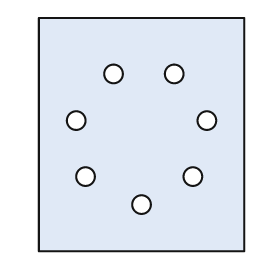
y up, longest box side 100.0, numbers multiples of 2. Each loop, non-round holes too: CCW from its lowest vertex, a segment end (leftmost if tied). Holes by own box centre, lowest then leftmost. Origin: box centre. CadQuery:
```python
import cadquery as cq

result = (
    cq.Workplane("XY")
    .moveTo(-44.0, -50.0)
    .lineTo(44.0, -50.0)
    .lineTo(44.0, 50.0)
    .lineTo(-44.0, 50.0)
    .close()
    .moveTo(0.0, -30.0)
    .circle(4.0)
    .moveTo(-24.0, -18.0)
    .circle(4.0)
    .moveTo(22.0, -18.0)
    .circle(4.0)
    .moveTo(-28.0, 6.0)
    .circle(4.0)
    .moveTo(28.0, 6.0)
    .circle(4.0)
    .moveTo(-12.0, 26.0)
    .circle(4.0)
    .moveTo(14.0, 26.0)
    .circle(4.0)
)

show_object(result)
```